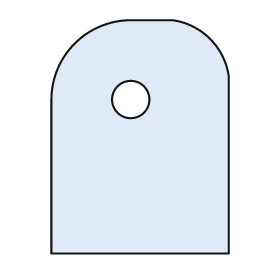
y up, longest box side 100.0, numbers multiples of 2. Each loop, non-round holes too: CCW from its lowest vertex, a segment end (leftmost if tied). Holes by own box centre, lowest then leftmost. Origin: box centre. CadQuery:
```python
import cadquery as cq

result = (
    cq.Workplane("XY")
    .moveTo(-38.0, -50.0)
    .lineTo(38.0, -50.0)
    .lineTo(38.0, 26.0)
    .threePointArc((30.0, 42.0), (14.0, 50.0))
    .lineTo(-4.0, 50.0)
    .threePointArc((-28.0, 40.0), (-38.0, 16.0))
    .close()
    .moveTo(-4.0, 16.0)
    .circle(8.0)
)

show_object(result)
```